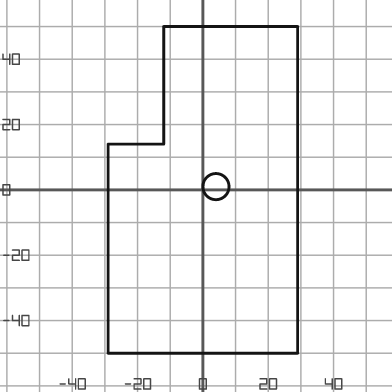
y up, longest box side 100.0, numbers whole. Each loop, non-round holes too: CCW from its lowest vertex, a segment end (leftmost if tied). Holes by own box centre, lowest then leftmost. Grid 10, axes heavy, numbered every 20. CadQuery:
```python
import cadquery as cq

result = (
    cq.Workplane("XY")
    .moveTo(-29.0, -50.0)
    .lineTo(29.0, -50.0)
    .lineTo(29.0, 50.0)
    .lineTo(-12.0, 50.0)
    .lineTo(-12.0, 14.0)
    .lineTo(-29.0, 14.0)
    .close()
    .moveTo(4.0, 1.0)
    .circle(4.0)
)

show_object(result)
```